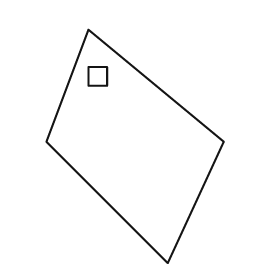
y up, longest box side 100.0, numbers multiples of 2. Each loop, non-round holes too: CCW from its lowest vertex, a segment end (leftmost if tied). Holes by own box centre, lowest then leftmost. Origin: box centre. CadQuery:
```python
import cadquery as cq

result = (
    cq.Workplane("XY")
    .moveTo(14.0, -50.0)
    .lineTo(38.0, 2.0)
    .lineTo(-20.0, 50.0)
    .lineTo(-38.0, 2.0)
    .close()
    .moveTo(-20.0, 26.0)
    .lineTo(-12.0, 26.0)
    .lineTo(-12.0, 34.0)
    .lineTo(-20.0, 34.0)
    .close()
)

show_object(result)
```